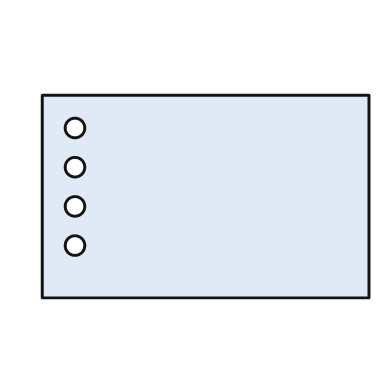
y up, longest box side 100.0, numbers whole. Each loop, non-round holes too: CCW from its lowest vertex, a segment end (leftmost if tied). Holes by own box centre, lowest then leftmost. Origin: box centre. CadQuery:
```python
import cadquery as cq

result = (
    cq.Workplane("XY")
    .moveTo(-50.0, -31.0)
    .lineTo(50.0, -31.0)
    .lineTo(50.0, 31.0)
    .lineTo(-50.0, 31.0)
    .close()
    .moveTo(-40.0, -15.0)
    .circle(3.0)
    .moveTo(-40.0, -3.0)
    .circle(3.0)
    .moveTo(-40.0, 9.0)
    .circle(3.0)
    .moveTo(-40.0, 21.0)
    .circle(3.0)
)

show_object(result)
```